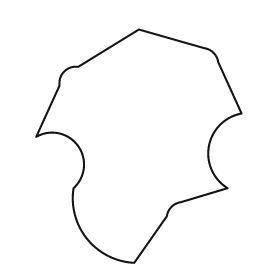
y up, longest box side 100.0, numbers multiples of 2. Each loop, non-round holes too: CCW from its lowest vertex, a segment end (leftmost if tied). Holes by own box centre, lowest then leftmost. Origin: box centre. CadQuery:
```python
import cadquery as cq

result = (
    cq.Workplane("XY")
    .moveTo(-2.0, -50.0)
    .lineTo(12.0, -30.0)
    .threePointArc((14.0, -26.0), (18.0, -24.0))
    .lineTo(38.0, -18.0)
    .threePointArc((30.0, 0.0), (44.0, 14.0))
    .lineTo(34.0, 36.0)
    .threePointArc((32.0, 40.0), (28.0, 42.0))
    .lineTo(0.0, 50.0)
    .lineTo(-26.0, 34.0)
    .threePointArc((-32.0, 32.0), (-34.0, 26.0))
    .lineTo(-44.0, 4.0)
    .threePointArc((-26.0, 0.0), (-28.0, -18.0))
    .threePointArc((-22.0, -40.0), (-2.0, -50.0))
    .close()
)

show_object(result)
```